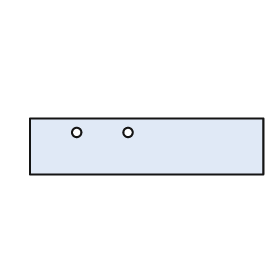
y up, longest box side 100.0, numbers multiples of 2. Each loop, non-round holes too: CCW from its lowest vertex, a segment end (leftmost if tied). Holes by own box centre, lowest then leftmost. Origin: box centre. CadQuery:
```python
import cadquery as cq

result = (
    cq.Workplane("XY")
    .moveTo(-50.0, -12.0)
    .lineTo(50.0, -12.0)
    .lineTo(50.0, 12.0)
    .lineTo(-50.0, 12.0)
    .close()
    .moveTo(-30.0, 6.0)
    .circle(2.0)
    .moveTo(-8.0, 6.0)
    .circle(2.0)
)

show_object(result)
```